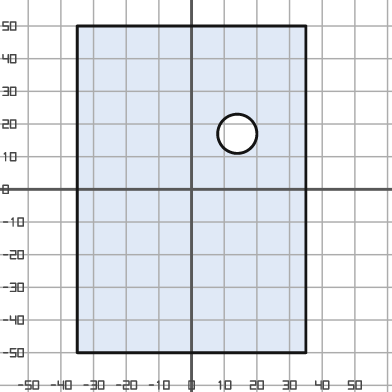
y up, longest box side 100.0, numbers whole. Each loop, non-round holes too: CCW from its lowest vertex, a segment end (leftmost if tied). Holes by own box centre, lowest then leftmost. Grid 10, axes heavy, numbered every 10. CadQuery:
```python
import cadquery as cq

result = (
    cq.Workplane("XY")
    .moveTo(-35.0, -50.0)
    .lineTo(35.0, -50.0)
    .lineTo(35.0, 50.0)
    .lineTo(-35.0, 50.0)
    .close()
    .moveTo(14.0, 17.0)
    .circle(6.0)
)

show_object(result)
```